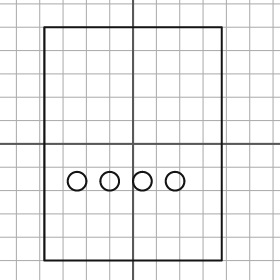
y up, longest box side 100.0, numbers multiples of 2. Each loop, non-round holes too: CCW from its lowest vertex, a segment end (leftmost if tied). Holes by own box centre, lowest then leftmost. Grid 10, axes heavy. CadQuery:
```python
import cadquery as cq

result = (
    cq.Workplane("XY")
    .moveTo(-38.0, -50.0)
    .lineTo(38.0, -50.0)
    .lineTo(38.0, 50.0)
    .lineTo(-38.0, 50.0)
    .close()
    .moveTo(-24.0, -16.0)
    .circle(4.0)
    .moveTo(-10.0, -16.0)
    .circle(4.0)
    .moveTo(4.0, -16.0)
    .circle(4.0)
    .moveTo(18.0, -16.0)
    .circle(4.0)
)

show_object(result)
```